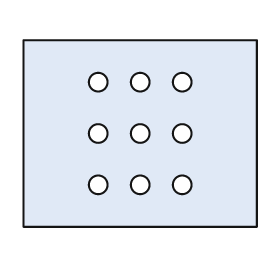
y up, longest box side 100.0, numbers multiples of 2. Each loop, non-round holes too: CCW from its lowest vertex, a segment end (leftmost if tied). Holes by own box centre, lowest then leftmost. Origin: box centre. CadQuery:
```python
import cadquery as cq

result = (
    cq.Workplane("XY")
    .moveTo(-50.0, -40.0)
    .lineTo(50.0, -40.0)
    .lineTo(50.0, 40.0)
    .lineTo(-50.0, 40.0)
    .close()
    .moveTo(-18.0, -22.0)
    .circle(4.0)
    .moveTo(0.0, -22.0)
    .circle(4.0)
    .moveTo(18.0, -22.0)
    .circle(4.0)
    .moveTo(-18.0, 0.0)
    .circle(4.0)
    .moveTo(0.0, 0.0)
    .circle(4.0)
    .moveTo(18.0, 0.0)
    .circle(4.0)
    .moveTo(-18.0, 22.0)
    .circle(4.0)
    .moveTo(0.0, 22.0)
    .circle(4.0)
    .moveTo(18.0, 22.0)
    .circle(4.0)
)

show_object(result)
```